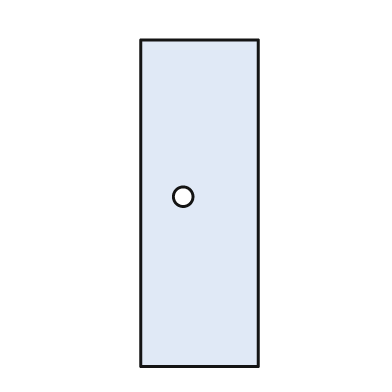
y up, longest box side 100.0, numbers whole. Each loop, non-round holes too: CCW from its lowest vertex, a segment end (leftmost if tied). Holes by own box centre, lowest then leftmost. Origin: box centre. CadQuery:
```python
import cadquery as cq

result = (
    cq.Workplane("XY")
    .moveTo(-18.0, -50.0)
    .lineTo(18.0, -50.0)
    .lineTo(18.0, 50.0)
    .lineTo(-18.0, 50.0)
    .close()
    .moveTo(-5.0, 2.0)
    .circle(3.0)
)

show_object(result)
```